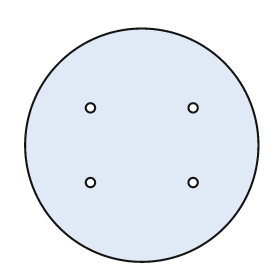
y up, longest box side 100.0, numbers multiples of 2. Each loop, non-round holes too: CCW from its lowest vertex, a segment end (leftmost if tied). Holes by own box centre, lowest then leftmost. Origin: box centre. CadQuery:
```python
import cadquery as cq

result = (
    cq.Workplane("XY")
    .moveTo(0.0, 0.0)
    .circle(50.0)
    .moveTo(-22.0, -16.0)
    .circle(2.0)
    .moveTo(22.0, -16.0)
    .circle(2.0)
    .moveTo(-22.0, 16.0)
    .circle(2.0)
    .moveTo(22.0, 16.0)
    .circle(2.0)
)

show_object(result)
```